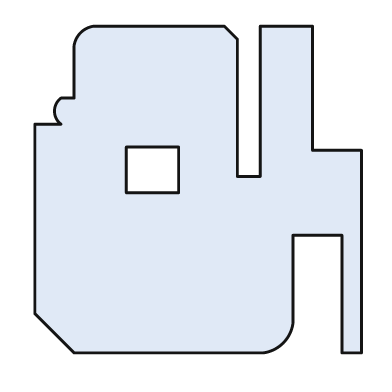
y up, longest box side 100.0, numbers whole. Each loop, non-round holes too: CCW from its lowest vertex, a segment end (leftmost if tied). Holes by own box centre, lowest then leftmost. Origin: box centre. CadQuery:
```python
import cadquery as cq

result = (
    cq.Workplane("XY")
    .moveTo(-38.0, -50.0)
    .lineTo(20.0, -50.0)
    .threePointArc((26.0, -47.0), (29.0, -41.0))
    .lineTo(29.0, -14.0)
    .lineTo(44.0, -14.0)
    .lineTo(44.0, -50.0)
    .lineTo(50.0, -50.0)
    .lineTo(50.0, 12.0)
    .lineTo(35.0, 12.0)
    .lineTo(35.0, 50.0)
    .lineTo(19.0, 50.0)
    .lineTo(19.0, 4.0)
    .lineTo(12.0, 4.0)
    .lineTo(12.0, 46.0)
    .lineTo(8.0, 50.0)
    .lineTo(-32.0, 50.0)
    .threePointArc((-36.0, 48.0), (-38.0, 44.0))
    .lineTo(-38.0, 28.0)
    .lineTo(-42.0, 28.0)
    .threePointArc((-44.0, 24.0), (-42.0, 20.0))
    .lineTo(-50.0, 20.0)
    .lineTo(-50.0, -38.0)
    .close()
    .moveTo(-22.0, -1.0)
    .lineTo(-6.0, -1.0)
    .lineTo(-6.0, 13.0)
    .lineTo(-22.0, 13.0)
    .close()
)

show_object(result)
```